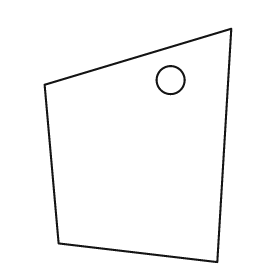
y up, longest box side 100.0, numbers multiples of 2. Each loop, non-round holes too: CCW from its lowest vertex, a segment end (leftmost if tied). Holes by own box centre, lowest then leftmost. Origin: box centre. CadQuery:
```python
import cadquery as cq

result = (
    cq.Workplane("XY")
    .moveTo(34.0, -50.0)
    .lineTo(40.0, 50.0)
    .lineTo(-40.0, 26.0)
    .lineTo(-34.0, -42.0)
    .close()
    .moveTo(14.0, 28.0)
    .circle(6.0)
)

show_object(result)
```